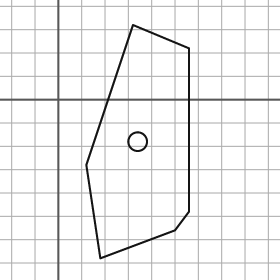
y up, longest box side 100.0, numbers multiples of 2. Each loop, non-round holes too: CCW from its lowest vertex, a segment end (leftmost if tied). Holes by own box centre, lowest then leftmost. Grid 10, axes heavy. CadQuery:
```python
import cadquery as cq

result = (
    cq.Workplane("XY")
    .moveTo(18.0, -68.0)
    .lineTo(50.0, -56.0)
    .lineTo(56.0, -48.0)
    .lineTo(56.0, 22.0)
    .lineTo(32.0, 32.0)
    .lineTo(12.0, -28.0)
    .close()
    .moveTo(34.0, -18.0)
    .circle(4.0)
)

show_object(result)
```